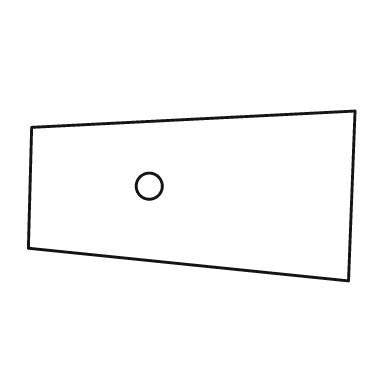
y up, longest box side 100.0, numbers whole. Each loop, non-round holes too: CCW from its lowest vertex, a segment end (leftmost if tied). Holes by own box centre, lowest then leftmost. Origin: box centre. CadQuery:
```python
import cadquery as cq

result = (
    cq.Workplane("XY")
    .moveTo(48.0, -26.0)
    .lineTo(50.0, 26.0)
    .lineTo(-49.0, 21.0)
    .lineTo(-50.0, -16.0)
    .close()
    .moveTo(-13.0, 3.0)
    .circle(4.0)
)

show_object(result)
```